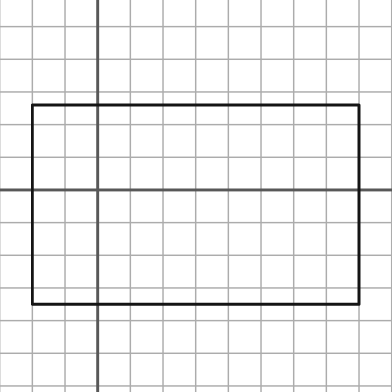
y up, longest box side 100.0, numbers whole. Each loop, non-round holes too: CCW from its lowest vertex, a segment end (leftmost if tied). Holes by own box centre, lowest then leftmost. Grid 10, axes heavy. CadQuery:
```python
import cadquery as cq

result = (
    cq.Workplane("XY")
    .moveTo(-20.0, -35.0)
    .lineTo(80.0, -35.0)
    .lineTo(80.0, 26.0)
    .lineTo(-20.0, 26.0)
    .close()
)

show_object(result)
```